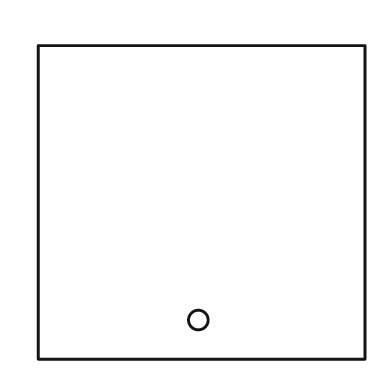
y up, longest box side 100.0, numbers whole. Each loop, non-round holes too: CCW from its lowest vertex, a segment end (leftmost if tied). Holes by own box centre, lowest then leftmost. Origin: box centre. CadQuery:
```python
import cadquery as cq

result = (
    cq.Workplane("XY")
    .moveTo(-50.0, -48.0)
    .lineTo(50.0, -48.0)
    .lineTo(50.0, 48.0)
    .lineTo(-50.0, 48.0)
    .close()
    .moveTo(-1.0, -36.0)
    .circle(3.0)
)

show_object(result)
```